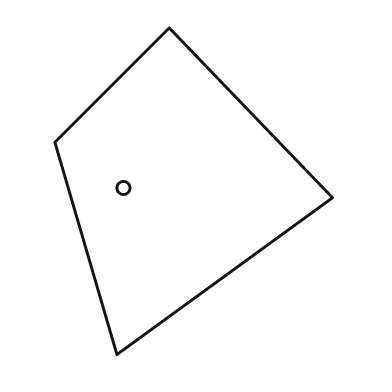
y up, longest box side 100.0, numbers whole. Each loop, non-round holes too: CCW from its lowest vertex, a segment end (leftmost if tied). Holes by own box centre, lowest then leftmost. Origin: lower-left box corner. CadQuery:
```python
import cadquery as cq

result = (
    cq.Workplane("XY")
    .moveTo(19.0, 0.0)
    .lineTo(85.0, 48.0)
    .lineTo(35.0, 100.0)
    .lineTo(0.0, 65.0)
    .close()
    .moveTo(21.0, 51.0)
    .circle(2.0)
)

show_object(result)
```